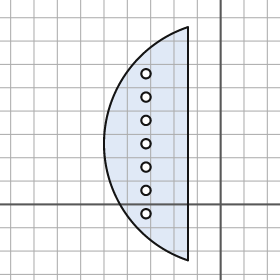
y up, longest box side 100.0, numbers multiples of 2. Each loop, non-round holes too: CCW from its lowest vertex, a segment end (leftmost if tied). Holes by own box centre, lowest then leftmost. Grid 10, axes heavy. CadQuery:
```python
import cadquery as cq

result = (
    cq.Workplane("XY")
    .moveTo(-14.0, -24.0)
    .lineTo(-14.0, 76.0)
    .threePointArc((-50.0, 26.0), (-14.0, -24.0))
    .close()
    .moveTo(-32.0, -4.0)
    .circle(2.0)
    .moveTo(-32.0, 6.0)
    .circle(2.0)
    .moveTo(-32.0, 16.0)
    .circle(2.0)
    .moveTo(-32.0, 26.0)
    .circle(2.0)
    .moveTo(-32.0, 36.0)
    .circle(2.0)
    .moveTo(-32.0, 46.0)
    .circle(2.0)
    .moveTo(-32.0, 56.0)
    .circle(2.0)
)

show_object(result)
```